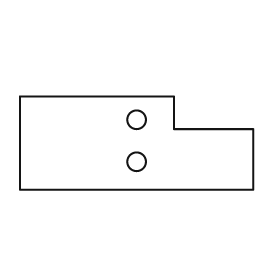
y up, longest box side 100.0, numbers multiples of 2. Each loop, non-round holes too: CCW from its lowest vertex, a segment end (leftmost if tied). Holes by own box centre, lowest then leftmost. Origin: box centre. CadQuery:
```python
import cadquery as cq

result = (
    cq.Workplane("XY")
    .moveTo(-50.0, -20.0)
    .lineTo(50.0, -20.0)
    .lineTo(50.0, 6.0)
    .lineTo(16.0, 6.0)
    .lineTo(16.0, 20.0)
    .lineTo(-50.0, 20.0)
    .close()
    .moveTo(0.0, -8.0)
    .circle(4.0)
    .moveTo(0.0, 10.0)
    .circle(4.0)
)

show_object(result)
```